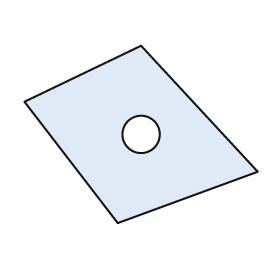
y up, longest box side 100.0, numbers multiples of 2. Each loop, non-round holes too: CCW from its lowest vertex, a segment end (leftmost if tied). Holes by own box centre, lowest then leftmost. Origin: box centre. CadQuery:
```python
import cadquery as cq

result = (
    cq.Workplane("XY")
    .moveTo(-10.0, -38.0)
    .lineTo(50.0, -16.0)
    .lineTo(0.0, 38.0)
    .lineTo(-50.0, 14.0)
    .close()
    .moveTo(0.0, 0.0)
    .circle(8.0)
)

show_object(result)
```